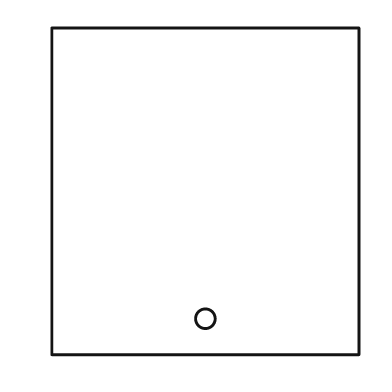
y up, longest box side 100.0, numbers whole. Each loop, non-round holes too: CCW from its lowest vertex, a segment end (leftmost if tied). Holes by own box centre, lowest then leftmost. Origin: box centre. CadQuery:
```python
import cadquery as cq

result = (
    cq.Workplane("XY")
    .moveTo(-47.0, -50.0)
    .lineTo(47.0, -50.0)
    .lineTo(47.0, 50.0)
    .lineTo(-47.0, 50.0)
    .close()
    .moveTo(0.0, -39.0)
    .circle(3.0)
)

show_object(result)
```